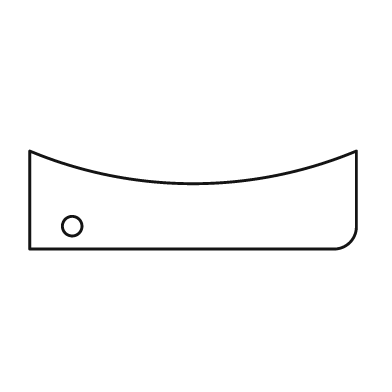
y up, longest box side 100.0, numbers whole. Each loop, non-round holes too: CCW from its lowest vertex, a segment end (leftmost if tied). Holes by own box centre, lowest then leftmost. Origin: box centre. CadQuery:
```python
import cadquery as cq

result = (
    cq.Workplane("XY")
    .moveTo(-50.0, -15.0)
    .lineTo(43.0, -15.0)
    .threePointArc((48.0, -13.0), (50.0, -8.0))
    .lineTo(50.0, 15.0)
    .threePointArc((0.0, 5.0), (-50.0, 15.0))
    .close()
    .moveTo(-37.0, -8.0)
    .circle(3.0)
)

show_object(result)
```